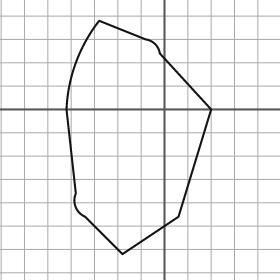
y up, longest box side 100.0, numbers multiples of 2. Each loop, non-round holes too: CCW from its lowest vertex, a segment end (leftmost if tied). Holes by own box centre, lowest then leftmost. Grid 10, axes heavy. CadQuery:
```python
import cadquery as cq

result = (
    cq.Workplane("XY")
    .moveTo(-18.0, -62.0)
    .lineTo(6.0, -46.0)
    .lineTo(20.0, 0.0)
    .lineTo(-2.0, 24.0)
    .threePointArc((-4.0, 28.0), (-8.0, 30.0))
    .lineTo(-28.0, 38.0)
    .threePointArc((-38.0, 20.0), (-42.0, 0.0))
    .lineTo(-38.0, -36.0)
    .threePointArc((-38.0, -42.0), (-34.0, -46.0))
    .close()
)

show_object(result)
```